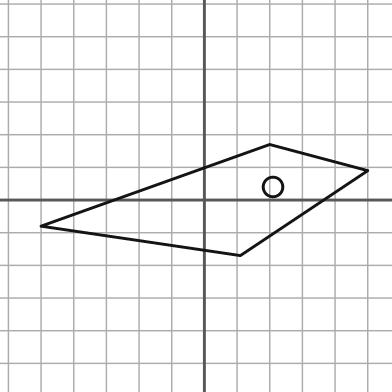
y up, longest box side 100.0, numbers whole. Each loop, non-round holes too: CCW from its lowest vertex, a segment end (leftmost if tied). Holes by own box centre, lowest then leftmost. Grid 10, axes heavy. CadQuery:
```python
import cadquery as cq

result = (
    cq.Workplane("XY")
    .moveTo(11.0, -17.0)
    .lineTo(50.0, 9.0)
    .lineTo(20.0, 17.0)
    .lineTo(-50.0, -8.0)
    .close()
    .moveTo(21.0, 4.0)
    .circle(3.0)
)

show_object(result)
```